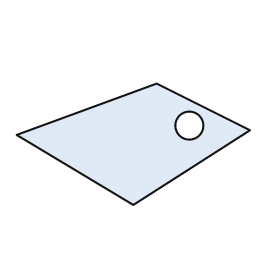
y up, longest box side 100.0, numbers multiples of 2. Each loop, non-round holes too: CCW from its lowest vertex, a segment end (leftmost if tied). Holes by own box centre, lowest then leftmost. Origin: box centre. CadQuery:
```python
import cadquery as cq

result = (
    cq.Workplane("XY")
    .moveTo(0.0, -26.0)
    .lineTo(50.0, 6.0)
    .lineTo(10.0, 26.0)
    .lineTo(-50.0, 4.0)
    .close()
    .moveTo(24.0, 8.0)
    .circle(6.0)
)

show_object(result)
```